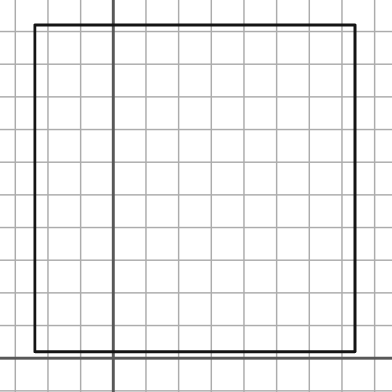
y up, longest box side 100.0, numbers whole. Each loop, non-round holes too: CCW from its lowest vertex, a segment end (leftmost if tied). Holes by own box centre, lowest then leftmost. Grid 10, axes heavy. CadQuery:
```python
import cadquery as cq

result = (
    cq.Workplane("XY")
    .moveTo(-24.0, 2.0)
    .lineTo(74.0, 2.0)
    .lineTo(74.0, 102.0)
    .lineTo(-24.0, 102.0)
    .close()
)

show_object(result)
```